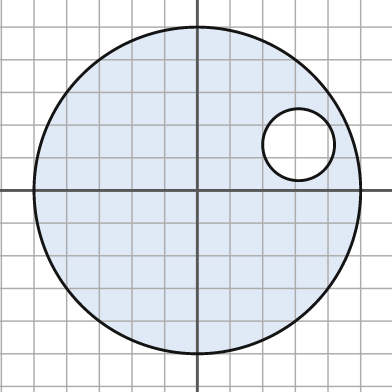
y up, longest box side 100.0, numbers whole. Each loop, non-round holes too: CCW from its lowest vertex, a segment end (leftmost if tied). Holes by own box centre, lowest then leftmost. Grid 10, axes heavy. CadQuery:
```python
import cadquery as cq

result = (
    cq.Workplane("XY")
    .moveTo(0.0, 0.0)
    .circle(50.0)
    .moveTo(31.0, 14.0)
    .circle(11.0)
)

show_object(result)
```